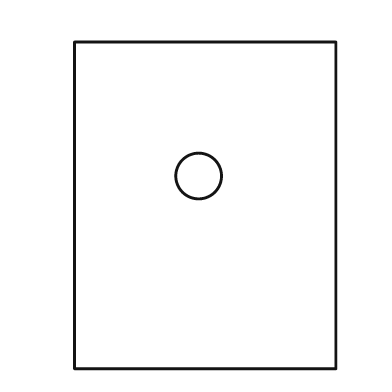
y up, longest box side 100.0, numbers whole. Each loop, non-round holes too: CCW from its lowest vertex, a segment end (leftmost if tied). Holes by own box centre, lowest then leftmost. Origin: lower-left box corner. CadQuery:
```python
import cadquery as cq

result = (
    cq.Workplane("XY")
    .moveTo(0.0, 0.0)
    .lineTo(80.0, 0.0)
    .lineTo(80.0, 100.0)
    .lineTo(0.0, 100.0)
    .close()
    .moveTo(38.0, 59.0)
    .circle(7.0)
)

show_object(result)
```